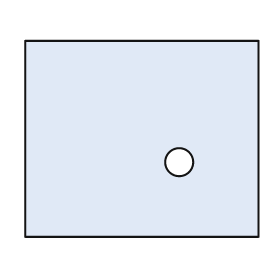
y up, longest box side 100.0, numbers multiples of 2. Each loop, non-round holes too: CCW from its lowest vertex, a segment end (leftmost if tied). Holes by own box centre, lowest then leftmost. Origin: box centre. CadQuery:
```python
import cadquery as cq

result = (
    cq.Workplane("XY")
    .moveTo(-50.0, -42.0)
    .lineTo(50.0, -42.0)
    .lineTo(50.0, 42.0)
    .lineTo(-50.0, 42.0)
    .close()
    .moveTo(16.0, -10.0)
    .circle(6.0)
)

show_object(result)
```